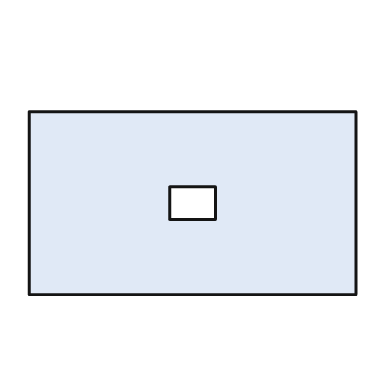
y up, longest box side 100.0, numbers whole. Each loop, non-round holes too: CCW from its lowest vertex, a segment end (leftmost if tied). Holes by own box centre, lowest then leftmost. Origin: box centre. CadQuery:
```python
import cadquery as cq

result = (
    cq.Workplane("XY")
    .moveTo(-50.0, -28.0)
    .lineTo(50.0, -28.0)
    .lineTo(50.0, 28.0)
    .lineTo(-50.0, 28.0)
    .close()
    .moveTo(-7.0, -5.0)
    .lineTo(7.0, -5.0)
    .lineTo(7.0, 5.0)
    .lineTo(-7.0, 5.0)
    .close()
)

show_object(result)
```